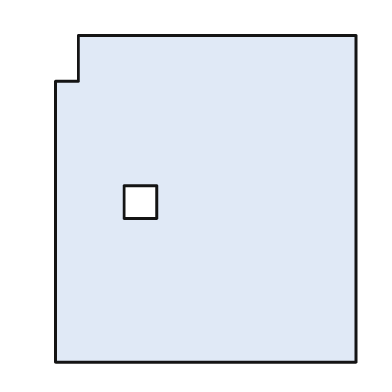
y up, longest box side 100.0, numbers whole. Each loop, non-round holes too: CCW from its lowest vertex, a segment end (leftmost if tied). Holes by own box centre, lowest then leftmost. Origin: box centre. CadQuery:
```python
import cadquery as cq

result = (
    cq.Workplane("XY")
    .moveTo(-46.0, -50.0)
    .lineTo(46.0, -50.0)
    .lineTo(46.0, 50.0)
    .lineTo(-39.0, 50.0)
    .lineTo(-39.0, 36.0)
    .lineTo(-46.0, 36.0)
    .close()
    .moveTo(-25.0, -6.0)
    .lineTo(-15.0, -6.0)
    .lineTo(-15.0, 4.0)
    .lineTo(-25.0, 4.0)
    .close()
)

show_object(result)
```